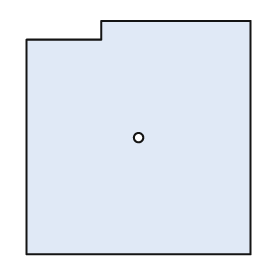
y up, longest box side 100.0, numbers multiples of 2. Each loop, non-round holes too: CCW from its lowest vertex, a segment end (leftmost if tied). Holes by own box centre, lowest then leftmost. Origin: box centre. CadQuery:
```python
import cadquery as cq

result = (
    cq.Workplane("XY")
    .moveTo(-48.0, -50.0)
    .lineTo(48.0, -50.0)
    .lineTo(48.0, 50.0)
    .lineTo(-16.0, 50.0)
    .lineTo(-16.0, 42.0)
    .lineTo(-48.0, 42.0)
    .close()
    .moveTo(0.0, 0.0)
    .circle(2.0)
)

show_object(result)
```